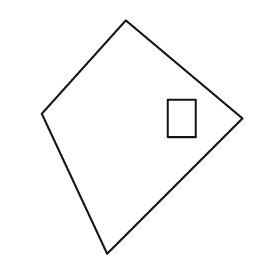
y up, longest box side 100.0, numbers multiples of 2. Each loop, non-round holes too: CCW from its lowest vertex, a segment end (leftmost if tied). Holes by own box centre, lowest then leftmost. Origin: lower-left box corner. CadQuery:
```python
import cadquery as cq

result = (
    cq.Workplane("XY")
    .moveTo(28.0, 0.0)
    .lineTo(86.0, 58.0)
    .lineTo(36.0, 100.0)
    .lineTo(0.0, 60.0)
    .close()
    .moveTo(54.0, 50.0)
    .lineTo(66.0, 50.0)
    .lineTo(66.0, 66.0)
    .lineTo(54.0, 66.0)
    .close()
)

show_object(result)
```